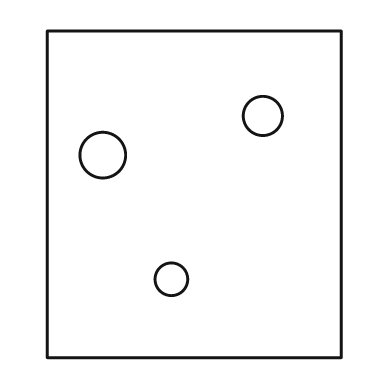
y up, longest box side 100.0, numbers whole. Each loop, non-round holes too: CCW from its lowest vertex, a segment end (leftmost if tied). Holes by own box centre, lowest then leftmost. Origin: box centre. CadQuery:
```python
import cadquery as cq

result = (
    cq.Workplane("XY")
    .moveTo(-45.0, -50.0)
    .lineTo(45.0, -50.0)
    .lineTo(45.0, 50.0)
    .lineTo(-45.0, 50.0)
    .close()
    .moveTo(-7.0, -26.0)
    .circle(5.0)
    .moveTo(-28.0, 12.0)
    .circle(7.0)
    .moveTo(21.0, 24.0)
    .circle(6.0)
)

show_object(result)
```